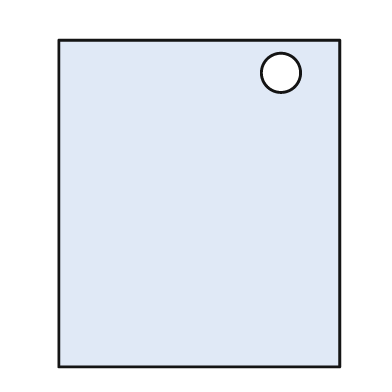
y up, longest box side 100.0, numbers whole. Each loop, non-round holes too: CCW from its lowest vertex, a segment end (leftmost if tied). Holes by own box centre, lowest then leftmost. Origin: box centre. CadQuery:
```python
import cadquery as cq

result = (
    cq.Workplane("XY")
    .moveTo(-43.0, -50.0)
    .lineTo(43.0, -50.0)
    .lineTo(43.0, 50.0)
    .lineTo(-43.0, 50.0)
    .close()
    .moveTo(25.0, 40.0)
    .circle(6.0)
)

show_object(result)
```